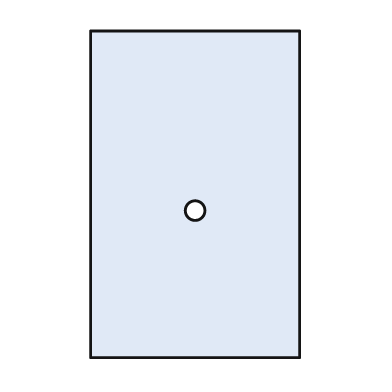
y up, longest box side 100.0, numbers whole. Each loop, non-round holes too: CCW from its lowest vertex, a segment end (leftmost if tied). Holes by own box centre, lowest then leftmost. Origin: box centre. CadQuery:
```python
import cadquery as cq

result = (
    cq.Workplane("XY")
    .moveTo(-32.0, -50.0)
    .lineTo(32.0, -50.0)
    .lineTo(32.0, 50.0)
    .lineTo(-32.0, 50.0)
    .close()
    .moveTo(0.0, -5.0)
    .circle(3.0)
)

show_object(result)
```